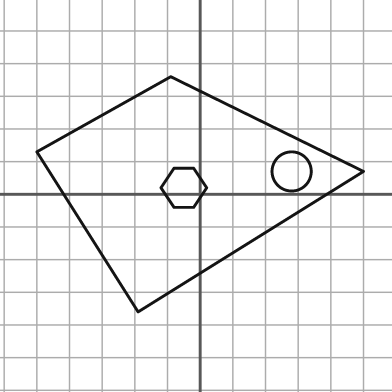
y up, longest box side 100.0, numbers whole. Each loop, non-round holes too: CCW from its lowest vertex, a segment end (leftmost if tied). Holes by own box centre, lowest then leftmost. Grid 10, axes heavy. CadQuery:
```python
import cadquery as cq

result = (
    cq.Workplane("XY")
    .moveTo(-19.0, -36.0)
    .lineTo(50.0, 7.0)
    .lineTo(-9.0, 36.0)
    .lineTo(-50.0, 13.0)
    .close()
    .moveTo(-8.0, -4.0)
    .lineTo(-2.0, -4.0)
    .lineTo(2.0, 2.0)
    .lineTo(-2.0, 8.0)
    .lineTo(-8.0, 8.0)
    .lineTo(-12.0, 2.0)
    .close()
    .moveTo(28.0, 7.0)
    .circle(6.0)
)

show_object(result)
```